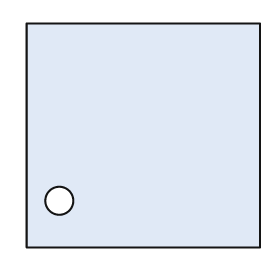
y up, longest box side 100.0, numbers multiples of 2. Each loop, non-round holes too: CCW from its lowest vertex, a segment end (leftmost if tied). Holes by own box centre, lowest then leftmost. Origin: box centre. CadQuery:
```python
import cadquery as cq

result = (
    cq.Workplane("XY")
    .moveTo(-50.0, -48.0)
    .lineTo(50.0, -48.0)
    .lineTo(50.0, 48.0)
    .lineTo(-50.0, 48.0)
    .close()
    .moveTo(-36.0, -28.0)
    .circle(6.0)
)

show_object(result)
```